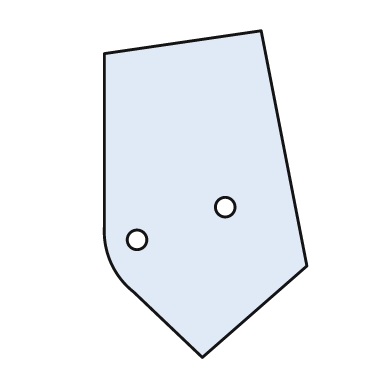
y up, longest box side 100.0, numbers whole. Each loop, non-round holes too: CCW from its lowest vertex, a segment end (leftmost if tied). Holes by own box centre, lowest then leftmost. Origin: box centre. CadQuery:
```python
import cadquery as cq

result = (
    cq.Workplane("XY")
    .moveTo(-1.0, -50.0)
    .lineTo(31.0, -22.0)
    .lineTo(17.0, 50.0)
    .lineTo(-31.0, 43.0)
    .lineTo(-31.0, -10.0)
    .threePointArc((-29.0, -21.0), (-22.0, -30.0))
    .close()
    .moveTo(-21.0, -14.0)
    .circle(3.0)
    .moveTo(6.0, -4.0)
    .circle(3.0)
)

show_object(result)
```